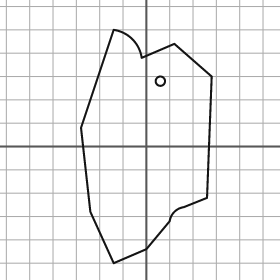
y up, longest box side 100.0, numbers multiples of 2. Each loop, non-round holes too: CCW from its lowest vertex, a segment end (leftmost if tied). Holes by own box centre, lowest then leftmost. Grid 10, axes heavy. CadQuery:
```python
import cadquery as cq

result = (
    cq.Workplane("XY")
    .moveTo(-14.0, -50.0)
    .lineTo(0.0, -44.0)
    .lineTo(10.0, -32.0)
    .threePointArc((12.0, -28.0), (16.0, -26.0))
    .lineTo(26.0, -22.0)
    .lineTo(28.0, 30.0)
    .lineTo(12.0, 44.0)
    .lineTo(-2.0, 38.0)
    .threePointArc((-6.0, 46.0), (-14.0, 50.0))
    .lineTo(-28.0, 8.0)
    .lineTo(-24.0, -28.0)
    .close()
    .moveTo(6.0, 28.0)
    .circle(2.0)
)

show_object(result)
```